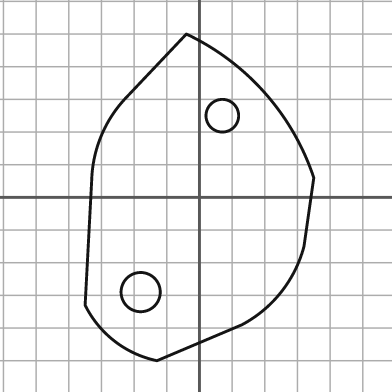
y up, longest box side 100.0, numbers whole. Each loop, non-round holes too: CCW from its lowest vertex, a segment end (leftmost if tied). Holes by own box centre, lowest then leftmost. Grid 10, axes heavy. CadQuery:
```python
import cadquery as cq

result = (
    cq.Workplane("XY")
    .moveTo(-13.0, -50.0)
    .lineTo(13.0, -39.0)
    .threePointArc((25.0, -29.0), (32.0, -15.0))
    .lineTo(35.0, 6.0)
    .threePointArc((20.0, 32.0), (-4.0, 50.0))
    .lineTo(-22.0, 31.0)
    .threePointArc((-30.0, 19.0), (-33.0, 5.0))
    .lineTo(-35.0, -33.0)
    .threePointArc((-26.0, -44.0), (-13.0, -50.0))
    .close()
    .moveTo(-18.0, -29.0)
    .circle(6.0)
    .moveTo(7.0, 25.0)
    .circle(5.0)
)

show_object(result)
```